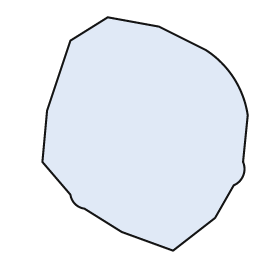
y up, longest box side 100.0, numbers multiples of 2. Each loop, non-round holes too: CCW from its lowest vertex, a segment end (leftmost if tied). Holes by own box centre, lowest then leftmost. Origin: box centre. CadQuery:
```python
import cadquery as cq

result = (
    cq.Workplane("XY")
    .moveTo(12.0, -50.0)
    .lineTo(30.0, -36.0)
    .lineTo(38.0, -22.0)
    .threePointArc((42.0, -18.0), (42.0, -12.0))
    .lineTo(44.0, 8.0)
    .threePointArc((38.0, 24.0), (26.0, 36.0))
    .lineTo(6.0, 46.0)
    .lineTo(-16.0, 50.0)
    .lineTo(-32.0, 40.0)
    .lineTo(-42.0, 10.0)
    .lineTo(-44.0, -12.0)
    .lineTo(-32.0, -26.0)
    .threePointArc((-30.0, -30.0), (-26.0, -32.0))
    .lineTo(-10.0, -42.0)
    .close()
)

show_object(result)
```